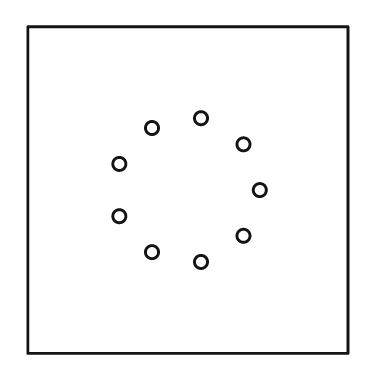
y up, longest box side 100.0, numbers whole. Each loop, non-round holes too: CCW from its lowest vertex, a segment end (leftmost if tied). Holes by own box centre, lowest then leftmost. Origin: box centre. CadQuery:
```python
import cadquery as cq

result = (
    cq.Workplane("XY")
    .moveTo(-49.0, -50.0)
    .lineTo(49.0, -50.0)
    .lineTo(49.0, 50.0)
    .lineTo(-49.0, 50.0)
    .close()
    .moveTo(4.0, -22.0)
    .circle(2.0)
    .moveTo(-11.0, -19.0)
    .circle(2.0)
    .moveTo(17.0, -14.0)
    .circle(2.0)
    .moveTo(-21.0, -8.0)
    .circle(2.0)
    .moveTo(22.0, 0.0)
    .circle(2.0)
    .moveTo(-21.0, 8.0)
    .circle(2.0)
    .moveTo(17.0, 14.0)
    .circle(2.0)
    .moveTo(-11.0, 19.0)
    .circle(2.0)
    .moveTo(4.0, 22.0)
    .circle(2.0)
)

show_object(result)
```